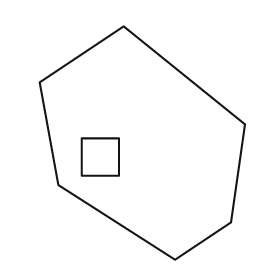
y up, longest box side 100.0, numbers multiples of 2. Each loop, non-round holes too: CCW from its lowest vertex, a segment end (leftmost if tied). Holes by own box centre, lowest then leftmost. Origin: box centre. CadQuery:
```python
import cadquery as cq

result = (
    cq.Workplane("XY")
    .moveTo(14.0, -50.0)
    .lineTo(38.0, -34.0)
    .lineTo(44.0, 8.0)
    .lineTo(-8.0, 50.0)
    .lineTo(-44.0, 26.0)
    .lineTo(-36.0, -18.0)
    .close()
    .moveTo(-26.0, -14.0)
    .lineTo(-10.0, -14.0)
    .lineTo(-10.0, 2.0)
    .lineTo(-26.0, 2.0)
    .close()
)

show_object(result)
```